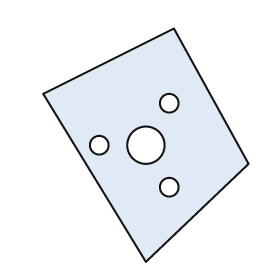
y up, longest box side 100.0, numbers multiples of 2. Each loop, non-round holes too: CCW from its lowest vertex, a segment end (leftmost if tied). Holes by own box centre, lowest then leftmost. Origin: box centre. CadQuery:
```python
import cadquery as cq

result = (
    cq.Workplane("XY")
    .moveTo(0.0, -50.0)
    .lineTo(44.0, -8.0)
    .lineTo(12.0, 50.0)
    .lineTo(-44.0, 22.0)
    .close()
    .moveTo(10.0, -18.0)
    .circle(4.0)
    .moveTo(-20.0, 0.0)
    .circle(4.0)
    .moveTo(0.0, 0.0)
    .circle(8.0)
    .moveTo(10.0, 18.0)
    .circle(4.0)
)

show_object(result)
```